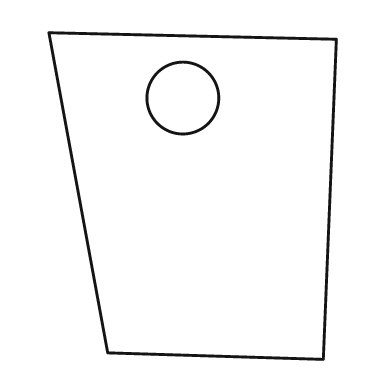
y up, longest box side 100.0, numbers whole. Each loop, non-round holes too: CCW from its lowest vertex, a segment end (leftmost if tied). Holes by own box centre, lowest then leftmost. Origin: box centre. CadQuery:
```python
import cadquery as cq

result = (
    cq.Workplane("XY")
    .moveTo(40.0, -50.0)
    .lineTo(44.0, 48.0)
    .lineTo(-44.0, 50.0)
    .lineTo(-26.0, -48.0)
    .close()
    .moveTo(-3.0, 30.0)
    .circle(11.0)
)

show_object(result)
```